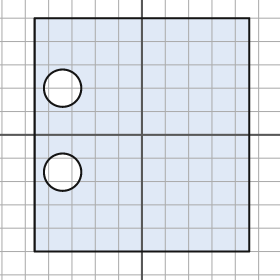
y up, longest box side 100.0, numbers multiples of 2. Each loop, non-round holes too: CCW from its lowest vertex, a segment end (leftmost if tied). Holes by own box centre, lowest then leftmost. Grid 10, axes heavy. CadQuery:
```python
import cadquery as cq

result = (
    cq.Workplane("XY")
    .moveTo(-46.0, -50.0)
    .lineTo(46.0, -50.0)
    .lineTo(46.0, 50.0)
    .lineTo(-46.0, 50.0)
    .close()
    .moveTo(-34.0, -16.0)
    .circle(8.0)
    .moveTo(-34.0, 20.0)
    .circle(8.0)
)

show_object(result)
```